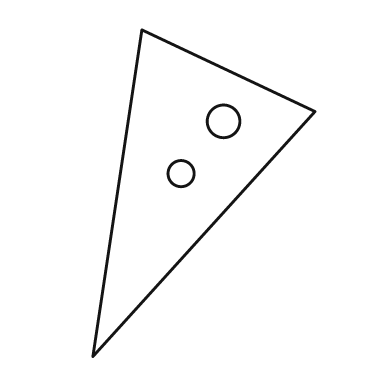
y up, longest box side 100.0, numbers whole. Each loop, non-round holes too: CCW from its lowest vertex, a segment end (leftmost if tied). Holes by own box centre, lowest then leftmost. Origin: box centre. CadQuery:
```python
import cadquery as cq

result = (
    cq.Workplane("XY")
    .moveTo(-34.0, -50.0)
    .lineTo(34.0, 25.0)
    .lineTo(-19.0, 50.0)
    .close()
    .moveTo(-7.0, 6.0)
    .circle(4.0)
    .moveTo(6.0, 22.0)
    .circle(5.0)
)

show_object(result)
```